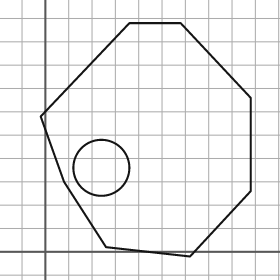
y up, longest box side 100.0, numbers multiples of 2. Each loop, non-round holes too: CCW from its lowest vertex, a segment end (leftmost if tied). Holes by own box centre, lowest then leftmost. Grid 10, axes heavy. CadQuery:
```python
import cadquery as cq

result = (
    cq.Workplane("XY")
    .moveTo(62.0, -2.0)
    .lineTo(88.0, 26.0)
    .lineTo(88.0, 66.0)
    .lineTo(58.0, 98.0)
    .lineTo(36.0, 98.0)
    .lineTo(-2.0, 58.0)
    .lineTo(8.0, 30.0)
    .lineTo(26.0, 2.0)
    .close()
    .moveTo(24.0, 36.0)
    .circle(12.0)
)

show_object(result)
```